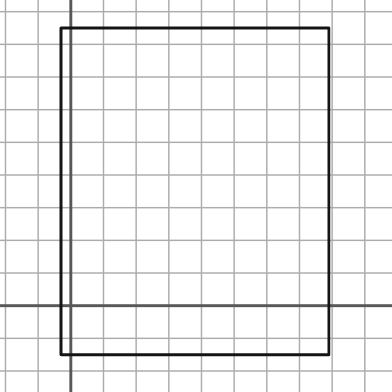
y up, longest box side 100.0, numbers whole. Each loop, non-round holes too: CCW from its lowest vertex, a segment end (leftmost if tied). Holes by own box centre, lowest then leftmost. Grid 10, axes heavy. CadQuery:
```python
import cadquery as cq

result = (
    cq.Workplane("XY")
    .moveTo(-3.0, -15.0)
    .lineTo(79.0, -15.0)
    .lineTo(79.0, 85.0)
    .lineTo(-3.0, 85.0)
    .close()
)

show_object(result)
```